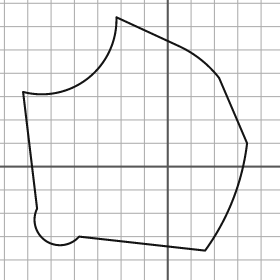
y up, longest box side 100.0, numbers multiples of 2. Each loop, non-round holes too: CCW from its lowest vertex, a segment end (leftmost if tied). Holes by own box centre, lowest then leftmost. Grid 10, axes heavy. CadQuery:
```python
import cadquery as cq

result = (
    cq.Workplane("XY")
    .moveTo(16.0, -36.0)
    .threePointArc((28.0, -14.0), (34.0, 10.0))
    .lineTo(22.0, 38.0)
    .threePointArc((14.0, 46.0), (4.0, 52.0))
    .lineTo(-22.0, 64.0)
    .threePointArc((-34.0, 38.0), (-62.0, 32.0))
    .lineTo(-56.0, -18.0)
    .threePointArc((-52.0, -32.0), (-38.0, -30.0))
    .close()
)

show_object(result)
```